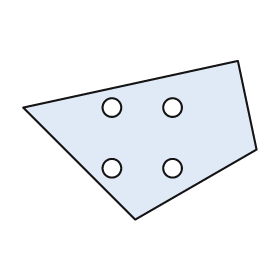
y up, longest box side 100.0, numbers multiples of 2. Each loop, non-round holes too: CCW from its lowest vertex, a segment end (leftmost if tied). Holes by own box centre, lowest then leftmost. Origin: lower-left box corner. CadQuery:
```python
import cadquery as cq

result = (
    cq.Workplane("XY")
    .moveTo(48.0, 0.0)
    .lineTo(100.0, 30.0)
    .lineTo(92.0, 68.0)
    .lineTo(0.0, 48.0)
    .close()
    .moveTo(38.0, 22.0)
    .circle(4.0)
    .moveTo(64.0, 22.0)
    .circle(4.0)
    .moveTo(38.0, 48.0)
    .circle(4.0)
    .moveTo(64.0, 48.0)
    .circle(4.0)
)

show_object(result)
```